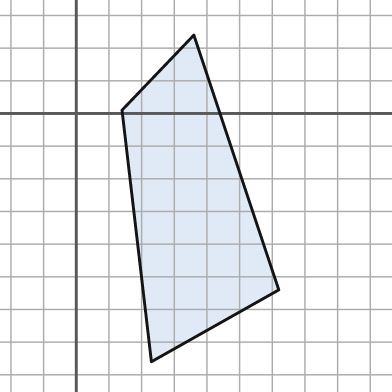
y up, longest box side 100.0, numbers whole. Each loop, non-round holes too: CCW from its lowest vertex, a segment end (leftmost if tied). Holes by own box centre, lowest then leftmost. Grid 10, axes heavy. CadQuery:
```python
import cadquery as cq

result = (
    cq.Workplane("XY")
    .moveTo(23.0, -76.0)
    .lineTo(62.0, -54.0)
    .lineTo(36.0, 24.0)
    .lineTo(14.0, 1.0)
    .close()
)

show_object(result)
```